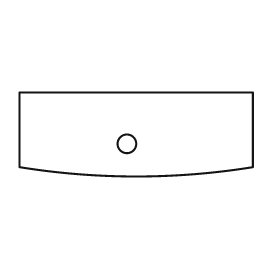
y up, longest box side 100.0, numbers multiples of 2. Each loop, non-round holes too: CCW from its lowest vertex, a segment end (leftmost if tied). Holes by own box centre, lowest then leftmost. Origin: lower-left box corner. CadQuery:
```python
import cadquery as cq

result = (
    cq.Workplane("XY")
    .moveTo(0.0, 4.0)
    .threePointArc((50.0, 0.0), (100.0, 4.0))
    .lineTo(100.0, 36.0)
    .lineTo(0.0, 36.0)
    .close()
    .moveTo(46.0, 14.0)
    .circle(4.0)
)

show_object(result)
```